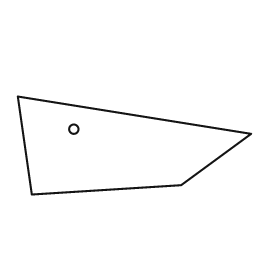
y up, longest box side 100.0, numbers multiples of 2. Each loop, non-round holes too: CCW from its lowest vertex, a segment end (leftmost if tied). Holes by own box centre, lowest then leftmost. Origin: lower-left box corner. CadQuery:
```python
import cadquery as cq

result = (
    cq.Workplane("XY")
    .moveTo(6.0, 0.0)
    .lineTo(70.0, 4.0)
    .lineTo(100.0, 26.0)
    .lineTo(0.0, 42.0)
    .close()
    .moveTo(24.0, 28.0)
    .circle(2.0)
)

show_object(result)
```